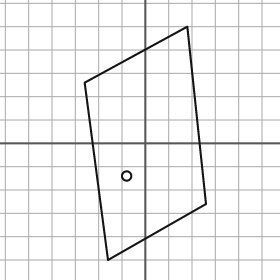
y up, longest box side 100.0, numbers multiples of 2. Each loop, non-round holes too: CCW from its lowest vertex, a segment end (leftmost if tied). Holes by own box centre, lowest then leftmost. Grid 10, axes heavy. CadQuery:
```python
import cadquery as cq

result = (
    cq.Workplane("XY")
    .moveTo(-16.0, -50.0)
    .lineTo(26.0, -26.0)
    .lineTo(18.0, 50.0)
    .lineTo(-26.0, 26.0)
    .close()
    .moveTo(-8.0, -14.0)
    .circle(2.0)
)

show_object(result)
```